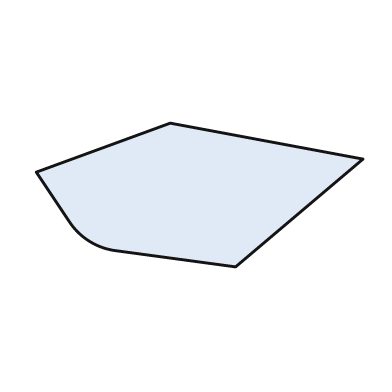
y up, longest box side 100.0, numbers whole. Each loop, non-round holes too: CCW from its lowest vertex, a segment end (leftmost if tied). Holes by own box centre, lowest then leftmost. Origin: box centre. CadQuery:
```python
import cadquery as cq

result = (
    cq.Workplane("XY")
    .moveTo(11.0, -22.0)
    .lineTo(50.0, 11.0)
    .lineTo(-9.0, 22.0)
    .lineTo(-50.0, 7.0)
    .lineTo(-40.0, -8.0)
    .threePointArc((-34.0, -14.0), (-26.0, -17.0))
    .close()
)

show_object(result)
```